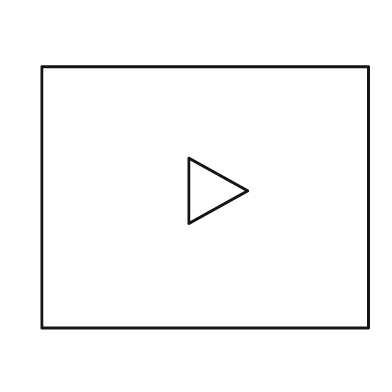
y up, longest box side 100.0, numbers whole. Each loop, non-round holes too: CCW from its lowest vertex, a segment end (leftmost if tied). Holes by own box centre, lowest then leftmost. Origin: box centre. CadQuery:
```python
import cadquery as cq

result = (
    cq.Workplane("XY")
    .moveTo(-50.0, -40.0)
    .lineTo(50.0, -40.0)
    .lineTo(50.0, 40.0)
    .lineTo(-50.0, 40.0)
    .close()
    .moveTo(-5.0, -8.0)
    .lineTo(13.0, 2.0)
    .lineTo(-5.0, 12.0)
    .close()
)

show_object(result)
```